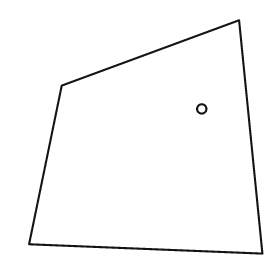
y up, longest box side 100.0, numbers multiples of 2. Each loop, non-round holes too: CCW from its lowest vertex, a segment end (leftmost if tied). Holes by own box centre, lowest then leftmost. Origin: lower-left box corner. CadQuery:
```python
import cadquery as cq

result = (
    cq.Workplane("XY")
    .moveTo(100.0, 0.0)
    .lineTo(90.0, 100.0)
    .lineTo(14.0, 72.0)
    .lineTo(0.0, 4.0)
    .close()
    .moveTo(74.0, 62.0)
    .circle(2.0)
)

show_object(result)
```